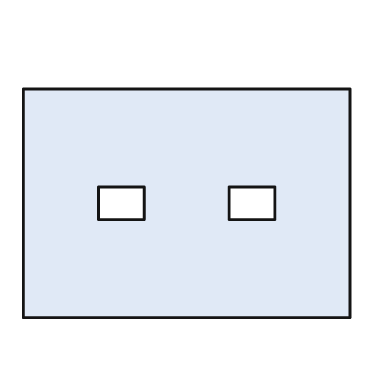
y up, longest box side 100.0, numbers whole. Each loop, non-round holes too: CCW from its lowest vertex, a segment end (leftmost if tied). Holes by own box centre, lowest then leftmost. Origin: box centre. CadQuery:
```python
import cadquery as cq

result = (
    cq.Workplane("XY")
    .moveTo(-50.0, -35.0)
    .lineTo(50.0, -35.0)
    .lineTo(50.0, 35.0)
    .lineTo(-50.0, 35.0)
    .close()
    .moveTo(-27.0, -5.0)
    .lineTo(-13.0, -5.0)
    .lineTo(-13.0, 5.0)
    .lineTo(-27.0, 5.0)
    .close()
    .moveTo(13.0, -5.0)
    .lineTo(27.0, -5.0)
    .lineTo(27.0, 5.0)
    .lineTo(13.0, 5.0)
    .close()
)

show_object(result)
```